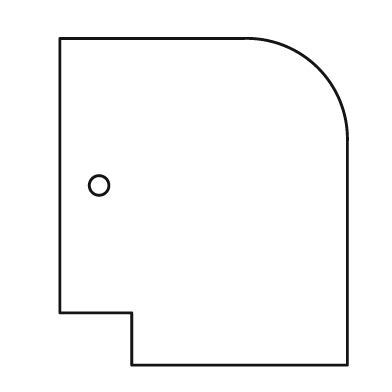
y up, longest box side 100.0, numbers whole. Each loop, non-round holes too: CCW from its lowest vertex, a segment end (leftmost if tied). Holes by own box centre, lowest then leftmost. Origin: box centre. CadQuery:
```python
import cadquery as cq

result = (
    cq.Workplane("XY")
    .moveTo(-22.0, -50.0)
    .lineTo(44.0, -50.0)
    .lineTo(44.0, 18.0)
    .threePointArc((35.0, 41.0), (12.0, 50.0))
    .lineTo(-44.0, 50.0)
    .lineTo(-44.0, -34.0)
    .lineTo(-22.0, -34.0)
    .close()
    .moveTo(-32.0, 5.0)
    .circle(3.0)
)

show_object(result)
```